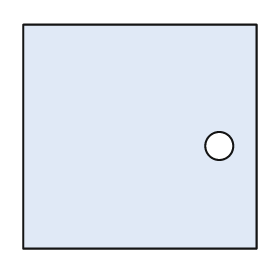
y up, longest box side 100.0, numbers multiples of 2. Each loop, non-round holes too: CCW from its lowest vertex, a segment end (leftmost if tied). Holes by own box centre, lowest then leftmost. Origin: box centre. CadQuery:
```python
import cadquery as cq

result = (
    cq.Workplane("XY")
    .moveTo(-50.0, -48.0)
    .lineTo(50.0, -48.0)
    .lineTo(50.0, 48.0)
    .lineTo(-50.0, 48.0)
    .close()
    .moveTo(34.0, -4.0)
    .circle(6.0)
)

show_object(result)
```